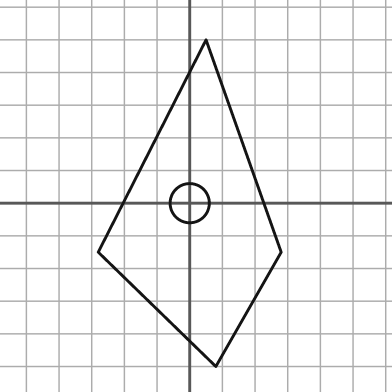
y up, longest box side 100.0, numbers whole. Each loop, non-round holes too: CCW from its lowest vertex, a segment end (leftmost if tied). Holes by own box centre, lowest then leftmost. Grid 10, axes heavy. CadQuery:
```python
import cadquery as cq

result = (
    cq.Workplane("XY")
    .moveTo(8.0, -50.0)
    .lineTo(28.0, -15.0)
    .lineTo(5.0, 50.0)
    .lineTo(-28.0, -15.0)
    .close()
    .moveTo(0.0, 0.0)
    .circle(6.0)
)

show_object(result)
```